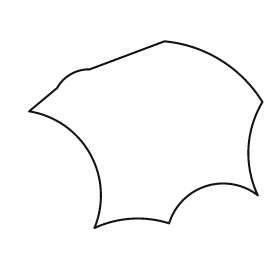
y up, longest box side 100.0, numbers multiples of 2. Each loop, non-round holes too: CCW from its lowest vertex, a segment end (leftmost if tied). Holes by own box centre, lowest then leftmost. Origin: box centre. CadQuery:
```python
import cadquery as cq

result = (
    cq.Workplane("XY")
    .moveTo(-22.0, -40.0)
    .threePointArc((-6.0, -36.0), (10.0, -38.0))
    .threePointArc((26.0, -22.0), (48.0, -26.0))
    .threePointArc((44.0, -6.0), (50.0, 14.0))
    .threePointArc((32.0, 32.0), (8.0, 40.0))
    .lineTo(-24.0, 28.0)
    .threePointArc((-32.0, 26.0), (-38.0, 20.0))
    .lineTo(-50.0, 10.0)
    .threePointArc((-24.0, -8.0), (-22.0, -40.0))
    .close()
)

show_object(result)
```